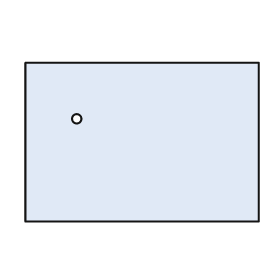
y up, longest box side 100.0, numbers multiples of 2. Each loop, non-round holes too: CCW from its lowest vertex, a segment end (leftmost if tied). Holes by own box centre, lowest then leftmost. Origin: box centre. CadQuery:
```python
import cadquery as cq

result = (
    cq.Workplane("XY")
    .moveTo(-50.0, -34.0)
    .lineTo(50.0, -34.0)
    .lineTo(50.0, 34.0)
    .lineTo(-50.0, 34.0)
    .close()
    .moveTo(-28.0, 10.0)
    .circle(2.0)
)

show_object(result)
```